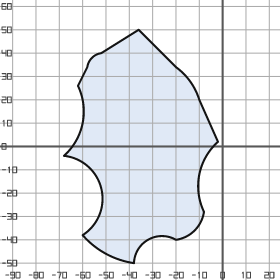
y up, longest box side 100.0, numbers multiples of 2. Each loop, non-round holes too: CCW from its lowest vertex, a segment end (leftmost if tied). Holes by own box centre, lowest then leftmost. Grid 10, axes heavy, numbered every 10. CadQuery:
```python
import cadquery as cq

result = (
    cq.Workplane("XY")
    .moveTo(-38.0, -50.0)
    .threePointArc((-32.0, -40.0), (-20.0, -40.0))
    .threePointArc((-12.0, -36.0), (-8.0, -28.0))
    .threePointArc((-10.0, -12.0), (-2.0, 2.0))
    .lineTo(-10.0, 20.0)
    .threePointArc((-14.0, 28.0), (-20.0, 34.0))
    .lineTo(-36.0, 50.0)
    .lineTo(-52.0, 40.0)
    .threePointArc((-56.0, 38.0), (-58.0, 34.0))
    .lineTo(-62.0, 26.0)
    .threePointArc((-60.0, 10.0), (-68.0, -4.0))
    .threePointArc((-52.0, -18.0), (-60.0, -38.0))
    .threePointArc((-50.0, -46.0), (-38.0, -50.0))
    .close()
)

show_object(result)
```